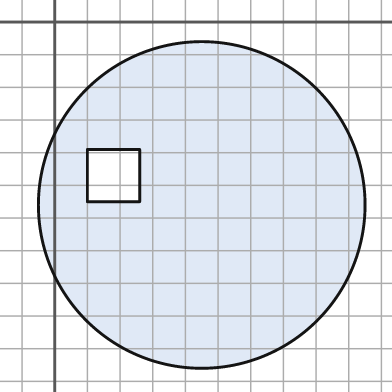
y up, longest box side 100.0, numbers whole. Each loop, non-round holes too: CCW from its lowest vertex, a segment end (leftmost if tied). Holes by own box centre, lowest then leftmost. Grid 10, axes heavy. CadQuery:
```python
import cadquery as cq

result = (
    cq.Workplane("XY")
    .moveTo(45.0, -56.0)
    .circle(50.0)
    .moveTo(10.0, -55.0)
    .lineTo(26.0, -55.0)
    .lineTo(26.0, -39.0)
    .lineTo(10.0, -39.0)
    .close()
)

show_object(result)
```